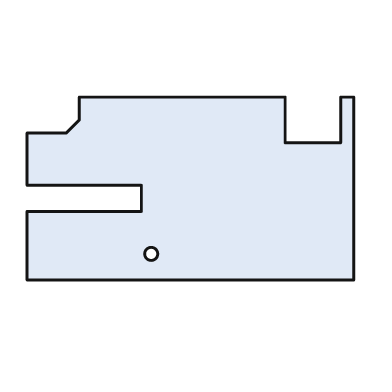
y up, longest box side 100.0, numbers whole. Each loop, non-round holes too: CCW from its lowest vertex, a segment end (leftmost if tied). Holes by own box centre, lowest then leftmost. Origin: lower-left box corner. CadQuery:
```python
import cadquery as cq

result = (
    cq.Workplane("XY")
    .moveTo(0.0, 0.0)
    .lineTo(100.0, 0.0)
    .lineTo(100.0, 56.0)
    .lineTo(96.0, 56.0)
    .lineTo(96.0, 42.0)
    .lineTo(79.0, 42.0)
    .lineTo(79.0, 56.0)
    .lineTo(16.0, 56.0)
    .lineTo(16.0, 49.0)
    .lineTo(12.0, 45.0)
    .lineTo(0.0, 45.0)
    .lineTo(0.0, 29.0)
    .lineTo(35.0, 29.0)
    .lineTo(35.0, 21.0)
    .lineTo(0.0, 21.0)
    .close()
    .moveTo(38.0, 8.0)
    .circle(2.0)
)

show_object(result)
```